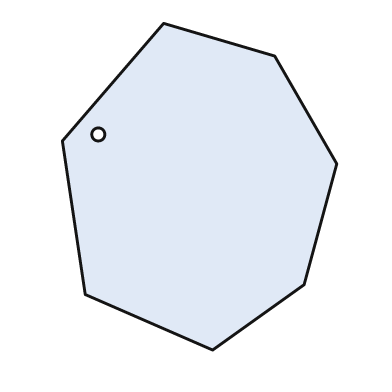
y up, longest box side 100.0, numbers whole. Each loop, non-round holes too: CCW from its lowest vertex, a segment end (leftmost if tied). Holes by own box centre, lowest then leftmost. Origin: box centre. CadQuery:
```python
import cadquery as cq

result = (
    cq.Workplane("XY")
    .moveTo(4.0, -50.0)
    .lineTo(32.0, -30.0)
    .lineTo(42.0, 7.0)
    .lineTo(23.0, 40.0)
    .lineTo(-11.0, 50.0)
    .lineTo(-42.0, 14.0)
    .lineTo(-35.0, -33.0)
    .close()
    .moveTo(-31.0, 16.0)
    .circle(2.0)
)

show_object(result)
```